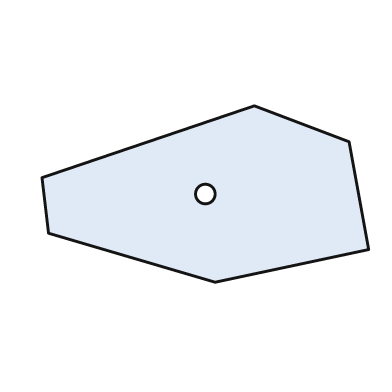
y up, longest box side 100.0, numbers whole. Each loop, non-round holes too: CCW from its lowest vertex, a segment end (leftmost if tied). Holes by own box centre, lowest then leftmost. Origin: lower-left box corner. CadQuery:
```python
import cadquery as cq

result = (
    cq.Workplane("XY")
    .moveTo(53.0, 0.0)
    .lineTo(100.0, 10.0)
    .lineTo(94.0, 43.0)
    .lineTo(65.0, 54.0)
    .lineTo(0.0, 32.0)
    .lineTo(2.0, 15.0)
    .close()
    .moveTo(50.0, 27.0)
    .circle(3.0)
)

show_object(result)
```